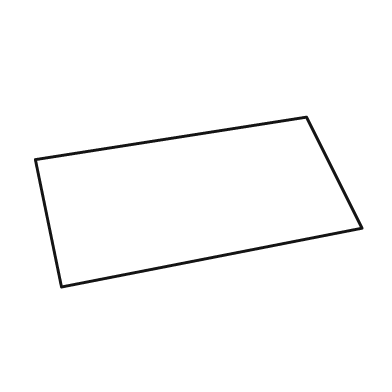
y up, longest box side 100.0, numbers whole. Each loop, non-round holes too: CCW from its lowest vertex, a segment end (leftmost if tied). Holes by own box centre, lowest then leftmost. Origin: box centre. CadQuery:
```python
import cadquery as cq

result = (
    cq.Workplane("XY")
    .moveTo(-42.0, -26.0)
    .lineTo(50.0, -8.0)
    .lineTo(33.0, 26.0)
    .lineTo(-50.0, 13.0)
    .close()
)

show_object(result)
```